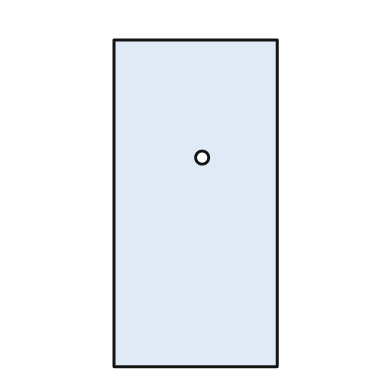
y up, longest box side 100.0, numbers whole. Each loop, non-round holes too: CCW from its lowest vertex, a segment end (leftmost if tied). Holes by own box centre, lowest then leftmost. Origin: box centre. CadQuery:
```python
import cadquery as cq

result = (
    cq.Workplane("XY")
    .moveTo(-25.0, -50.0)
    .lineTo(25.0, -50.0)
    .lineTo(25.0, 50.0)
    .lineTo(-25.0, 50.0)
    .close()
    .moveTo(2.0, 14.0)
    .circle(2.0)
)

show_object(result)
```